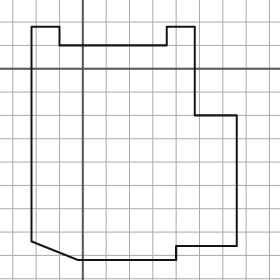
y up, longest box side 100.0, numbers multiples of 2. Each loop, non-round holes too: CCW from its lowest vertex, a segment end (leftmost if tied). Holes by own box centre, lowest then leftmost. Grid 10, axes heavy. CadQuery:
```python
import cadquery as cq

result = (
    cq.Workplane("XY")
    .moveTo(-2.0, -82.0)
    .lineTo(40.0, -82.0)
    .lineTo(40.0, -76.0)
    .lineTo(66.0, -76.0)
    .lineTo(66.0, -20.0)
    .lineTo(48.0, -20.0)
    .lineTo(48.0, 18.0)
    .lineTo(36.0, 18.0)
    .lineTo(36.0, 10.0)
    .lineTo(-10.0, 10.0)
    .lineTo(-10.0, 18.0)
    .lineTo(-22.0, 18.0)
    .lineTo(-22.0, -74.0)
    .close()
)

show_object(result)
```